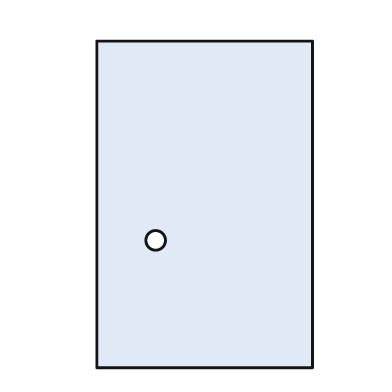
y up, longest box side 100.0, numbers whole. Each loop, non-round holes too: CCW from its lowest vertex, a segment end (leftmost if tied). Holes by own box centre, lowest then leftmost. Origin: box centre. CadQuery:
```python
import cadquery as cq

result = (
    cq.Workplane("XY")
    .moveTo(-33.0, -50.0)
    .lineTo(33.0, -50.0)
    .lineTo(33.0, 50.0)
    .lineTo(-33.0, 50.0)
    .close()
    .moveTo(-15.0, -11.0)
    .circle(3.0)
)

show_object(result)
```